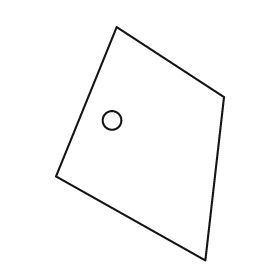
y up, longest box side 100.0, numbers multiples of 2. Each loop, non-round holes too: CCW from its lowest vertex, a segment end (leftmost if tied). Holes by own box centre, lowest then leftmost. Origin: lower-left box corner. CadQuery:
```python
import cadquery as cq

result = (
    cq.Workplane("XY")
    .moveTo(64.0, 0.0)
    .lineTo(72.0, 70.0)
    .lineTo(26.0, 100.0)
    .lineTo(0.0, 36.0)
    .close()
    .moveTo(24.0, 60.0)
    .circle(4.0)
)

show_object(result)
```